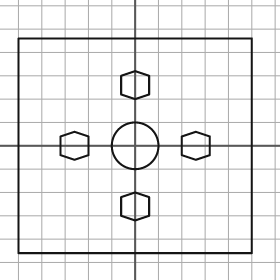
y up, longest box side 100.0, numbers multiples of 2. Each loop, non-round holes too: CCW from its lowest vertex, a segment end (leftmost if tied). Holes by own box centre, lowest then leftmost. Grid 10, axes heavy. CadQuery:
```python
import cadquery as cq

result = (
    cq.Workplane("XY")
    .moveTo(-50.0, -46.0)
    .lineTo(50.0, -46.0)
    .lineTo(50.0, 46.0)
    .lineTo(-50.0, 46.0)
    .close()
    .moveTo(0.0, -32.0)
    .lineTo(6.0, -30.0)
    .lineTo(6.0, -22.0)
    .lineTo(0.0, -20.0)
    .lineTo(-6.0, -22.0)
    .lineTo(-6.0, -30.0)
    .close()
    .moveTo(-26.0, -6.0)
    .lineTo(-20.0, -4.0)
    .lineTo(-20.0, 4.0)
    .lineTo(-26.0, 6.0)
    .lineTo(-32.0, 4.0)
    .lineTo(-32.0, -4.0)
    .close()
    .moveTo(0.0, 0.0)
    .circle(10.0)
    .moveTo(26.0, -6.0)
    .lineTo(32.0, -4.0)
    .lineTo(32.0, 4.0)
    .lineTo(26.0, 6.0)
    .lineTo(20.0, 4.0)
    .lineTo(20.0, -4.0)
    .close()
    .moveTo(0.0, 20.0)
    .lineTo(6.0, 22.0)
    .lineTo(6.0, 30.0)
    .lineTo(0.0, 32.0)
    .lineTo(-6.0, 30.0)
    .lineTo(-6.0, 22.0)
    .close()
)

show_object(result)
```